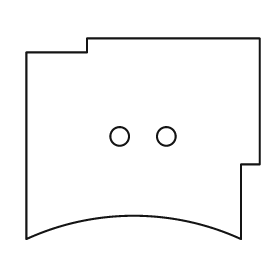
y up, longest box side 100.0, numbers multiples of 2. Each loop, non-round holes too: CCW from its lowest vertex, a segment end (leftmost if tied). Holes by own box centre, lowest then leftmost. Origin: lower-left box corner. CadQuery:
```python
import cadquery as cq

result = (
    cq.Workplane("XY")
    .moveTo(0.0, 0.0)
    .threePointArc((46.0, 10.0), (92.0, 0.0))
    .lineTo(92.0, 32.0)
    .lineTo(100.0, 32.0)
    .lineTo(100.0, 86.0)
    .lineTo(26.0, 86.0)
    .lineTo(26.0, 80.0)
    .lineTo(0.0, 80.0)
    .close()
    .moveTo(40.0, 44.0)
    .circle(4.0)
    .moveTo(60.0, 44.0)
    .circle(4.0)
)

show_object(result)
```